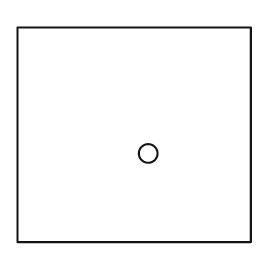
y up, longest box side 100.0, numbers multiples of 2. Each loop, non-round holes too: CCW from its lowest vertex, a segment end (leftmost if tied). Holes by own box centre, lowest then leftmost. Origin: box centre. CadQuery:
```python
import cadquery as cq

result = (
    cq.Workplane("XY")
    .moveTo(-50.0, -46.0)
    .lineTo(50.0, -46.0)
    .lineTo(50.0, 46.0)
    .lineTo(-50.0, 46.0)
    .close()
    .moveTo(6.0, -8.0)
    .circle(4.0)
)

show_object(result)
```